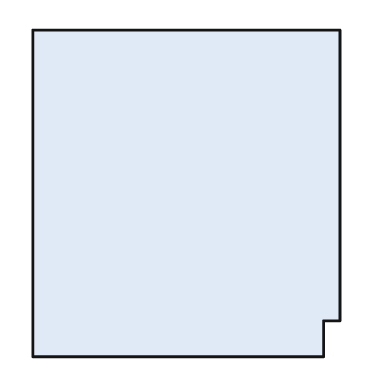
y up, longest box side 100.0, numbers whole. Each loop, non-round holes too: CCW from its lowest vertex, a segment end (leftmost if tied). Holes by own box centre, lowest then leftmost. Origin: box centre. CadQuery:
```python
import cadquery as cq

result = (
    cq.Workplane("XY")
    .moveTo(-47.0, -50.0)
    .lineTo(42.0, -50.0)
    .lineTo(42.0, -39.0)
    .lineTo(47.0, -39.0)
    .lineTo(47.0, 50.0)
    .lineTo(-47.0, 50.0)
    .close()
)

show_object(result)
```